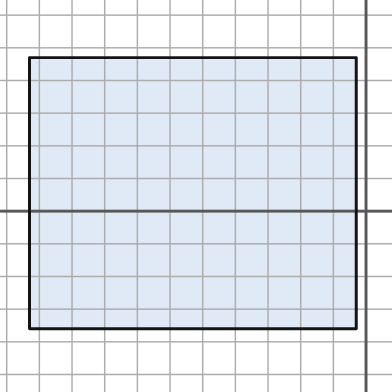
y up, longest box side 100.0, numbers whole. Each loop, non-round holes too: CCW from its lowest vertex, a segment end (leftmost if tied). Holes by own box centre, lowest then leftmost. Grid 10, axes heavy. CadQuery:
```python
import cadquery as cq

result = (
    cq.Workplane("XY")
    .moveTo(-103.0, -36.0)
    .lineTo(-3.0, -36.0)
    .lineTo(-3.0, 47.0)
    .lineTo(-103.0, 47.0)
    .close()
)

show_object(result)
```